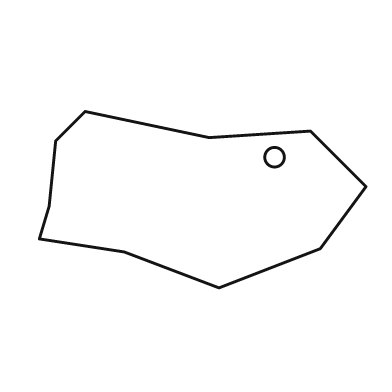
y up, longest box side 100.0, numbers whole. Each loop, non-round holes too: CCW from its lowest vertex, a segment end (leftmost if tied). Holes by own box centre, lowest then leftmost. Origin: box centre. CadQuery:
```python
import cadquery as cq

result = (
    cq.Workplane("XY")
    .moveTo(5.0, -27.0)
    .lineTo(36.0, -15.0)
    .lineTo(50.0, 4.0)
    .lineTo(33.0, 21.0)
    .lineTo(2.0, 19.0)
    .lineTo(-36.0, 27.0)
    .lineTo(-45.0, 18.0)
    .lineTo(-47.0, -2.0)
    .lineTo(-50.0, -12.0)
    .lineTo(-24.0, -16.0)
    .close()
    .moveTo(22.0, 13.0)
    .circle(3.0)
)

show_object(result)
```